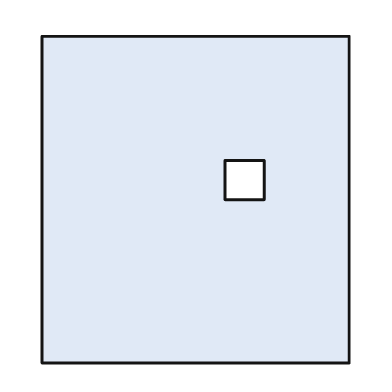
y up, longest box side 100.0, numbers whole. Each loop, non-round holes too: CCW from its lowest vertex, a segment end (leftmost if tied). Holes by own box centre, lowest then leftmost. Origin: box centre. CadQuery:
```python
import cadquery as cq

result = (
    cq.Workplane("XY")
    .moveTo(-47.0, -50.0)
    .lineTo(47.0, -50.0)
    .lineTo(47.0, 50.0)
    .lineTo(-47.0, 50.0)
    .close()
    .moveTo(9.0, 0.0)
    .lineTo(21.0, 0.0)
    .lineTo(21.0, 12.0)
    .lineTo(9.0, 12.0)
    .close()
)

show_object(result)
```